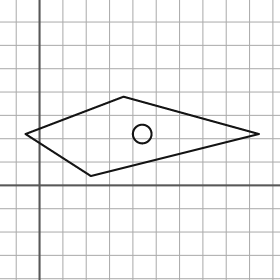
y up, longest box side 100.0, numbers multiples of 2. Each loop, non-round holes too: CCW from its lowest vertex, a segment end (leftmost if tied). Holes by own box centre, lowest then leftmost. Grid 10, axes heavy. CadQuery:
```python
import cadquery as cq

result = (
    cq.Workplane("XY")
    .moveTo(22.0, 4.0)
    .lineTo(94.0, 22.0)
    .lineTo(36.0, 38.0)
    .lineTo(-6.0, 22.0)
    .close()
    .moveTo(44.0, 22.0)
    .circle(4.0)
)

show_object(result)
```